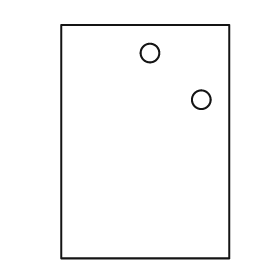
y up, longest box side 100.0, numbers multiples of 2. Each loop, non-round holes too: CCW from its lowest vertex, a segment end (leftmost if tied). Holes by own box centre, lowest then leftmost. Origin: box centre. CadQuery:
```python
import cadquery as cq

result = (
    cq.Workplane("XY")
    .moveTo(-36.0, -50.0)
    .lineTo(36.0, -50.0)
    .lineTo(36.0, 50.0)
    .lineTo(-36.0, 50.0)
    .close()
    .moveTo(24.0, 18.0)
    .circle(4.0)
    .moveTo(2.0, 38.0)
    .circle(4.0)
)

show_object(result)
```